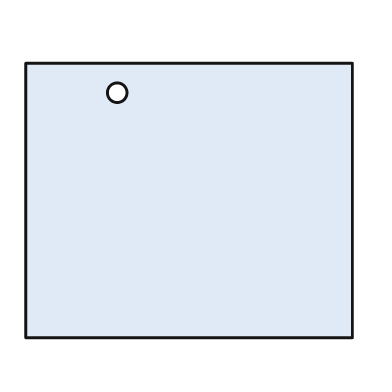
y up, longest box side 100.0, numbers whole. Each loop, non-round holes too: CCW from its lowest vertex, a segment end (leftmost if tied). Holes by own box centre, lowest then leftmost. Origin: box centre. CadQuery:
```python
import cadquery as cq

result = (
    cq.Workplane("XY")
    .moveTo(-50.0, -42.0)
    .lineTo(50.0, -42.0)
    .lineTo(50.0, 42.0)
    .lineTo(-50.0, 42.0)
    .close()
    .moveTo(-22.0, 33.0)
    .circle(3.0)
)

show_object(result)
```